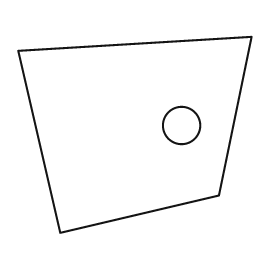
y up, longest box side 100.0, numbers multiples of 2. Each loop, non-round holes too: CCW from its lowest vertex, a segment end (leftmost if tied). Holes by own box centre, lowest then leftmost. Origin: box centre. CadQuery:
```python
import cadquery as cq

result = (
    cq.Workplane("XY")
    .moveTo(-32.0, -42.0)
    .lineTo(36.0, -26.0)
    .lineTo(50.0, 42.0)
    .lineTo(-50.0, 36.0)
    .close()
    .moveTo(20.0, 4.0)
    .circle(8.0)
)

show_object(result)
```